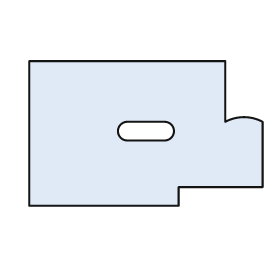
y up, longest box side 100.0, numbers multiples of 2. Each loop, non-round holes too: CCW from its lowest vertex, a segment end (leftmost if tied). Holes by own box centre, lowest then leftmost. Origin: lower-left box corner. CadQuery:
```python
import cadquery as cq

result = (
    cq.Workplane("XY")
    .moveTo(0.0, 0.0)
    .lineTo(64.0, 0.0)
    .lineTo(64.0, 8.0)
    .lineTo(100.0, 8.0)
    .lineTo(100.0, 36.0)
    .threePointArc((92.0, 38.0), (84.0, 36.0))
    .lineTo(84.0, 62.0)
    .lineTo(0.0, 62.0)
    .close()
    .moveTo(42.0, 28.0)
    .lineTo(58.0, 28.0)
    .threePointArc((62.0, 32.0), (58.0, 36.0))
    .lineTo(42.0, 36.0)
    .threePointArc((38.0, 32.0), (42.0, 28.0))
    .close()
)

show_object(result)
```